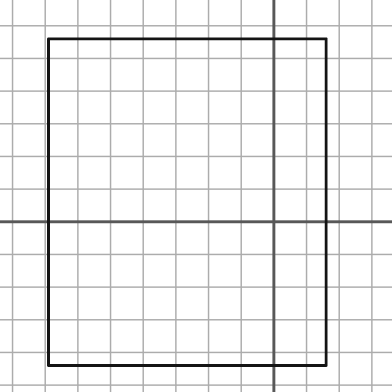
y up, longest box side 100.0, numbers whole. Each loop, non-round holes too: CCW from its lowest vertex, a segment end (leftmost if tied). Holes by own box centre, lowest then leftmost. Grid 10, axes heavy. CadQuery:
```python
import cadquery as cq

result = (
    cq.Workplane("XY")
    .moveTo(-69.0, -44.0)
    .lineTo(16.0, -44.0)
    .lineTo(16.0, 56.0)
    .lineTo(-69.0, 56.0)
    .close()
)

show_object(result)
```